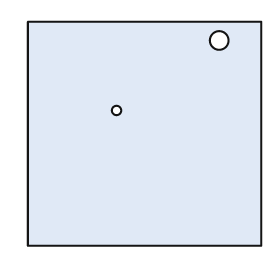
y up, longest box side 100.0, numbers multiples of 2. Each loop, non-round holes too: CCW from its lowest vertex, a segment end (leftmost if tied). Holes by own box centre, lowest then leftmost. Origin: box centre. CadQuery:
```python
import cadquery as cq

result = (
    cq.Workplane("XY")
    .moveTo(-50.0, -48.0)
    .lineTo(50.0, -48.0)
    .lineTo(50.0, 48.0)
    .lineTo(-50.0, 48.0)
    .close()
    .moveTo(-12.0, 10.0)
    .circle(2.0)
    .moveTo(32.0, 40.0)
    .circle(4.0)
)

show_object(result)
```